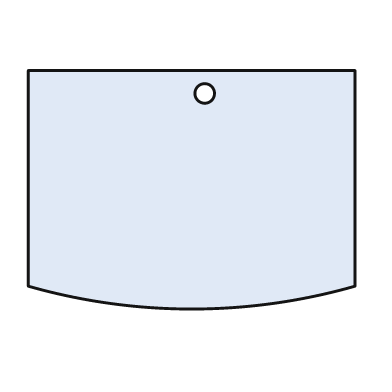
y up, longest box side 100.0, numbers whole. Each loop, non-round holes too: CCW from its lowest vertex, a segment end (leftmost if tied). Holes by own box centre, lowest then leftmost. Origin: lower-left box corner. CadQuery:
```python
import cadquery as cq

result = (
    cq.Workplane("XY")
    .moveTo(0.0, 7.0)
    .threePointArc((50.0, 0.0), (100.0, 7.0))
    .lineTo(100.0, 73.0)
    .lineTo(0.0, 73.0)
    .close()
    .moveTo(54.0, 66.0)
    .circle(3.0)
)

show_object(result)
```